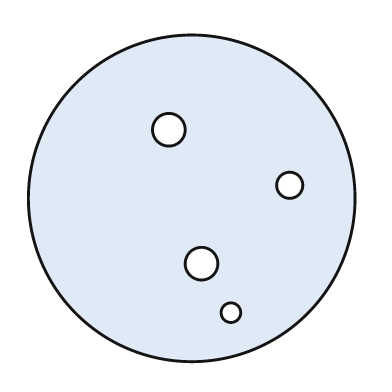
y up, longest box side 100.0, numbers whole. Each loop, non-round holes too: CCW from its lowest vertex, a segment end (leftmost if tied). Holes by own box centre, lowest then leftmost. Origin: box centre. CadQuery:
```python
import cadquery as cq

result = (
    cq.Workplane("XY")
    .moveTo(0.0, 0.0)
    .circle(50.0)
    .moveTo(12.0, -35.0)
    .circle(3.0)
    .moveTo(3.0, -20.0)
    .circle(5.0)
    .moveTo(30.0, 4.0)
    .circle(4.0)
    .moveTo(-7.0, 21.0)
    .circle(5.0)
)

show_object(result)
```